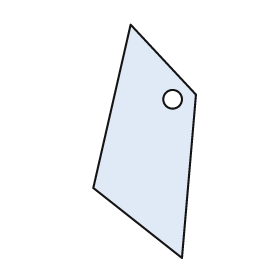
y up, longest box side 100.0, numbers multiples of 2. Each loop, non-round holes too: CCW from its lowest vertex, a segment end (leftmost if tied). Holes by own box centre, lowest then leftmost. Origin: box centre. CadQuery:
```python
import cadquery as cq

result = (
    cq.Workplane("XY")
    .moveTo(16.0, -50.0)
    .lineTo(22.0, 20.0)
    .lineTo(-6.0, 50.0)
    .lineTo(-22.0, -20.0)
    .close()
    .moveTo(12.0, 18.0)
    .circle(4.0)
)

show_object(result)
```